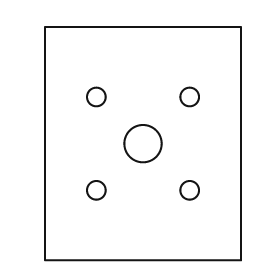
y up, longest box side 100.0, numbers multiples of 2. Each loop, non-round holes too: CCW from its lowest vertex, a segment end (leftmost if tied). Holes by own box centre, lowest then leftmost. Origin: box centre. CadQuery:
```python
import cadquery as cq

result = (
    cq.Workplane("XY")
    .moveTo(-42.0, -50.0)
    .lineTo(42.0, -50.0)
    .lineTo(42.0, 50.0)
    .lineTo(-42.0, 50.0)
    .close()
    .moveTo(-20.0, -20.0)
    .circle(4.0)
    .moveTo(20.0, -20.0)
    .circle(4.0)
    .moveTo(0.0, 0.0)
    .circle(8.0)
    .moveTo(-20.0, 20.0)
    .circle(4.0)
    .moveTo(20.0, 20.0)
    .circle(4.0)
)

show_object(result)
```